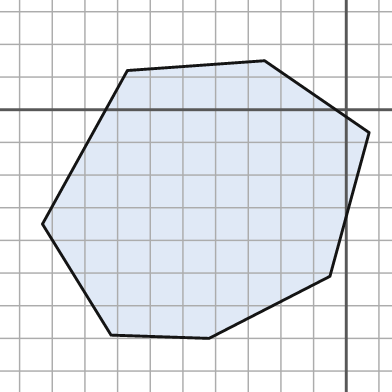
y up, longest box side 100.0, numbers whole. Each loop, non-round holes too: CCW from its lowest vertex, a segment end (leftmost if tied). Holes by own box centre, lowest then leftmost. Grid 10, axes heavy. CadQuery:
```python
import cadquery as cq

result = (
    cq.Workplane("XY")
    .moveTo(-42.0, -70.0)
    .lineTo(-5.0, -51.0)
    .lineTo(7.0, -7.0)
    .lineTo(-25.0, 15.0)
    .lineTo(-67.0, 12.0)
    .lineTo(-93.0, -35.0)
    .lineTo(-72.0, -69.0)
    .close()
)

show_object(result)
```